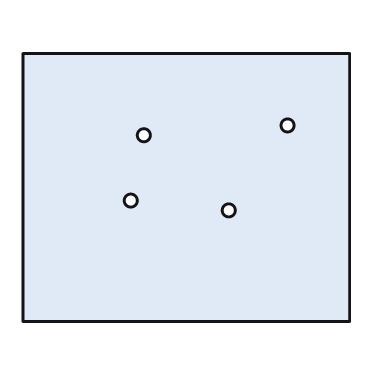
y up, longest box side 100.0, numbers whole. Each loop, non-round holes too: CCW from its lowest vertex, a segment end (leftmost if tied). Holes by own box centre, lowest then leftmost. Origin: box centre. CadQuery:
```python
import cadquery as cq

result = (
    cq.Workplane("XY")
    .moveTo(-50.0, -41.0)
    .lineTo(50.0, -41.0)
    .lineTo(50.0, 41.0)
    .lineTo(-50.0, 41.0)
    .close()
    .moveTo(13.0, -7.0)
    .circle(2.0)
    .moveTo(-17.0, -4.0)
    .circle(2.0)
    .moveTo(-13.0, 16.0)
    .circle(2.0)
    .moveTo(31.0, 19.0)
    .circle(2.0)
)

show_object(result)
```